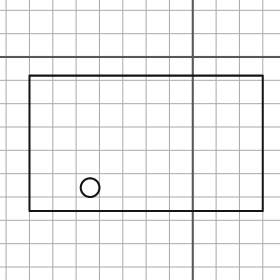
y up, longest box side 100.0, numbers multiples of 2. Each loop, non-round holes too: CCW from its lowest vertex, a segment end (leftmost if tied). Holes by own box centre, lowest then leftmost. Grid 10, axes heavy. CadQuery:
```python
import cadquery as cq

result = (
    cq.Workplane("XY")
    .moveTo(-70.0, -66.0)
    .lineTo(30.0, -66.0)
    .lineTo(30.0, -8.0)
    .lineTo(-70.0, -8.0)
    .close()
    .moveTo(-44.0, -56.0)
    .circle(4.0)
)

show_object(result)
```